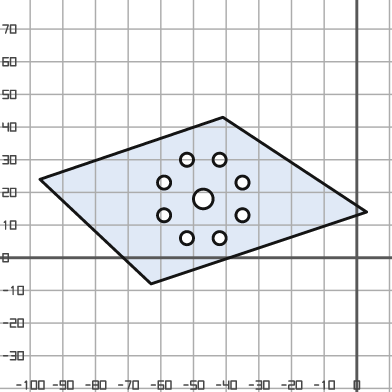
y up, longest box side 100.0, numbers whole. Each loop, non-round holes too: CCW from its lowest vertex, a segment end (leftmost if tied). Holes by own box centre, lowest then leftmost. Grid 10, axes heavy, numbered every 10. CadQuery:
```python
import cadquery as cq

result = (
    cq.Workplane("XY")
    .moveTo(-63.0, -8.0)
    .lineTo(3.0, 14.0)
    .lineTo(-41.0, 43.0)
    .lineTo(-97.0, 24.0)
    .close()
    .moveTo(-52.0, 6.0)
    .circle(2.0)
    .moveTo(-42.0, 6.0)
    .circle(2.0)
    .moveTo(-59.0, 13.0)
    .circle(2.0)
    .moveTo(-35.0, 13.0)
    .circle(2.0)
    .moveTo(-47.0, 18.0)
    .circle(3.0)
    .moveTo(-59.0, 23.0)
    .circle(2.0)
    .moveTo(-35.0, 23.0)
    .circle(2.0)
    .moveTo(-52.0, 30.0)
    .circle(2.0)
    .moveTo(-42.0, 30.0)
    .circle(2.0)
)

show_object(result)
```